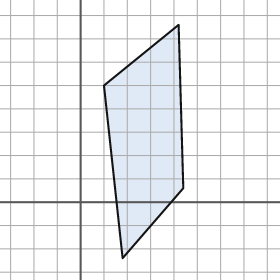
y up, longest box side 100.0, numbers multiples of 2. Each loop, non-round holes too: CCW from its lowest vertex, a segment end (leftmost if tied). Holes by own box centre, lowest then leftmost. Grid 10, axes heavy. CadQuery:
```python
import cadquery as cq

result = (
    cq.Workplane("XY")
    .moveTo(18.0, -24.0)
    .lineTo(44.0, 6.0)
    .lineTo(42.0, 76.0)
    .lineTo(10.0, 50.0)
    .close()
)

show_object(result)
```